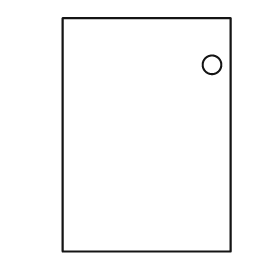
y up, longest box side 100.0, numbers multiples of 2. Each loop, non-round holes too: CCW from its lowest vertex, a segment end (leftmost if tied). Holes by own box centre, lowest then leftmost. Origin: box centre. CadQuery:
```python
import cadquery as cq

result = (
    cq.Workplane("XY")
    .moveTo(-36.0, -50.0)
    .lineTo(36.0, -50.0)
    .lineTo(36.0, 50.0)
    .lineTo(-36.0, 50.0)
    .close()
    .moveTo(28.0, 30.0)
    .circle(4.0)
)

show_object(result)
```